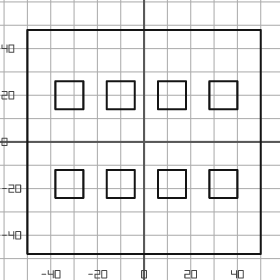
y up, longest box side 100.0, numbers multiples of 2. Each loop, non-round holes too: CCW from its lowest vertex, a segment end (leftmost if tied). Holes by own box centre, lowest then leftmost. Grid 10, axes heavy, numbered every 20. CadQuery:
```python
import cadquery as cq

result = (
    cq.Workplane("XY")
    .moveTo(-50.0, -48.0)
    .lineTo(50.0, -48.0)
    .lineTo(50.0, 48.0)
    .lineTo(-50.0, 48.0)
    .close()
    .moveTo(-38.0, -24.0)
    .lineTo(-26.0, -24.0)
    .lineTo(-26.0, -12.0)
    .lineTo(-38.0, -12.0)
    .close()
    .moveTo(-16.0, -24.0)
    .lineTo(-4.0, -24.0)
    .lineTo(-4.0, -12.0)
    .lineTo(-16.0, -12.0)
    .close()
    .moveTo(6.0, -24.0)
    .lineTo(18.0, -24.0)
    .lineTo(18.0, -12.0)
    .lineTo(6.0, -12.0)
    .close()
    .moveTo(28.0, -24.0)
    .lineTo(40.0, -24.0)
    .lineTo(40.0, -12.0)
    .lineTo(28.0, -12.0)
    .close()
    .moveTo(-38.0, 14.0)
    .lineTo(-26.0, 14.0)
    .lineTo(-26.0, 26.0)
    .lineTo(-38.0, 26.0)
    .close()
    .moveTo(-16.0, 14.0)
    .lineTo(-4.0, 14.0)
    .lineTo(-4.0, 26.0)
    .lineTo(-16.0, 26.0)
    .close()
    .moveTo(6.0, 14.0)
    .lineTo(18.0, 14.0)
    .lineTo(18.0, 26.0)
    .lineTo(6.0, 26.0)
    .close()
    .moveTo(28.0, 14.0)
    .lineTo(40.0, 14.0)
    .lineTo(40.0, 26.0)
    .lineTo(28.0, 26.0)
    .close()
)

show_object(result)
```